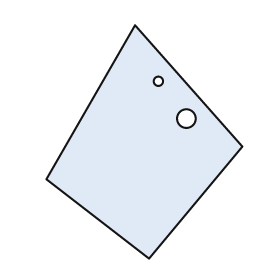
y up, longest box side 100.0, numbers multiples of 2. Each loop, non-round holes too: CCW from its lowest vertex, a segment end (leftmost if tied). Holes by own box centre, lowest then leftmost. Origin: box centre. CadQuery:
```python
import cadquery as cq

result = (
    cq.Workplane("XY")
    .moveTo(2.0, -50.0)
    .lineTo(42.0, -2.0)
    .lineTo(-4.0, 50.0)
    .lineTo(-42.0, -16.0)
    .close()
    .moveTo(18.0, 10.0)
    .circle(4.0)
    .moveTo(6.0, 26.0)
    .circle(2.0)
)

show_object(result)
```